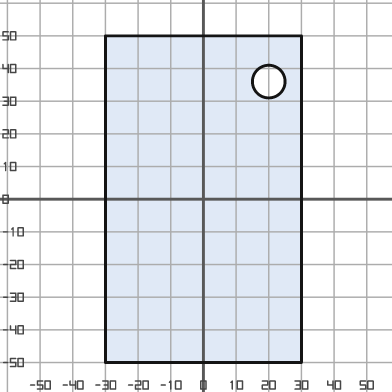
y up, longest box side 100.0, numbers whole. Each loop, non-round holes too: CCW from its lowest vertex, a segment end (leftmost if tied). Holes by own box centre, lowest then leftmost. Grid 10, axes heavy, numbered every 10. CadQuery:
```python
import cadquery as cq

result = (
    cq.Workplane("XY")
    .moveTo(-30.0, -50.0)
    .lineTo(30.0, -50.0)
    .lineTo(30.0, 50.0)
    .lineTo(-30.0, 50.0)
    .close()
    .moveTo(20.0, 36.0)
    .circle(5.0)
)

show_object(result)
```